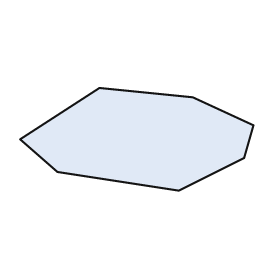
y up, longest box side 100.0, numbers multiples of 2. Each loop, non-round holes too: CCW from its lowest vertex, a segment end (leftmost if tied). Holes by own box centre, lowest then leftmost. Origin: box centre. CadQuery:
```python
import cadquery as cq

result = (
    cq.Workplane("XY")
    .moveTo(18.0, -22.0)
    .lineTo(46.0, -8.0)
    .lineTo(50.0, 6.0)
    .lineTo(24.0, 18.0)
    .lineTo(-16.0, 22.0)
    .lineTo(-50.0, 0.0)
    .lineTo(-34.0, -14.0)
    .close()
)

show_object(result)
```